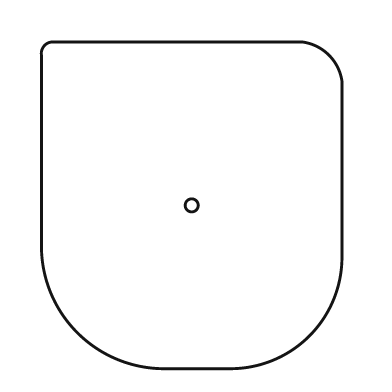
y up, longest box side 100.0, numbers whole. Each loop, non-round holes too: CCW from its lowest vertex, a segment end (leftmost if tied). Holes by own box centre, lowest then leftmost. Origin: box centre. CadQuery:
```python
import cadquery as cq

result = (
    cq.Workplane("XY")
    .moveTo(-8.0, -50.0)
    .lineTo(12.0, -50.0)
    .threePointArc((36.0, -40.0), (46.0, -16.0))
    .lineTo(46.0, 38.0)
    .threePointArc((42.0, 46.0), (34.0, 50.0))
    .lineTo(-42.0, 50.0)
    .threePointArc((-45.0, 49.0), (-46.0, 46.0))
    .lineTo(-46.0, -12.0)
    .threePointArc((-35.0, -39.0), (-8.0, -50.0))
    .close()
    .moveTo(0.0, 0.0)
    .circle(2.0)
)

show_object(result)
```